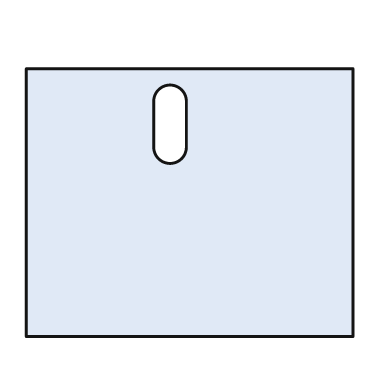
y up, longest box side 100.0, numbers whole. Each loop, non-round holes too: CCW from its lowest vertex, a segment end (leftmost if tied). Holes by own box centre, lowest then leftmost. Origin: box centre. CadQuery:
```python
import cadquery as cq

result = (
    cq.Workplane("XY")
    .moveTo(-50.0, -41.0)
    .lineTo(50.0, -41.0)
    .lineTo(50.0, 41.0)
    .lineTo(-50.0, 41.0)
    .close()
    .moveTo(-11.0, 17.0)
    .threePointArc((-6.0, 12.0), (-1.0, 17.0))
    .lineTo(-1.0, 31.0)
    .threePointArc((-6.0, 36.0), (-11.0, 31.0))
    .close()
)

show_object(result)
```